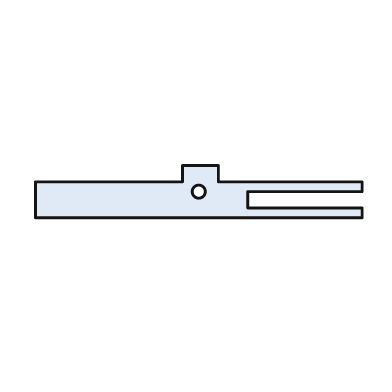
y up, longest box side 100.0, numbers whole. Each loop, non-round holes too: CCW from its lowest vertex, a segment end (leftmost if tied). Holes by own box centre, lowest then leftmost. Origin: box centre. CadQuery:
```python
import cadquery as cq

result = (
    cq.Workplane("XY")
    .moveTo(-50.0, -8.0)
    .lineTo(50.0, -8.0)
    .lineTo(50.0, -5.0)
    .lineTo(15.0, -5.0)
    .lineTo(15.0, 0.0)
    .lineTo(50.0, 0.0)
    .lineTo(50.0, 3.0)
    .lineTo(6.0, 3.0)
    .lineTo(6.0, 8.0)
    .lineTo(-5.0, 8.0)
    .lineTo(-5.0, 3.0)
    .lineTo(-50.0, 3.0)
    .close()
    .moveTo(0.0, 0.0)
    .circle(2.0)
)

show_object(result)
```